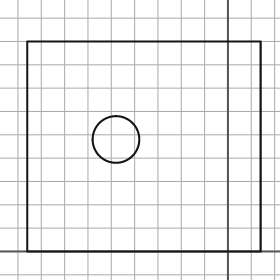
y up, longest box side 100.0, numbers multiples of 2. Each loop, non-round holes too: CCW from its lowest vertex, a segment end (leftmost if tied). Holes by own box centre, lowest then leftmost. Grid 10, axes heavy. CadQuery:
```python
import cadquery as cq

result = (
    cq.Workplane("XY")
    .moveTo(-86.0, 0.0)
    .lineTo(14.0, 0.0)
    .lineTo(14.0, 90.0)
    .lineTo(-86.0, 90.0)
    .close()
    .moveTo(-48.0, 48.0)
    .circle(10.0)
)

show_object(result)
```